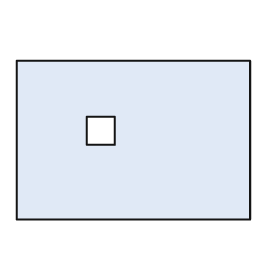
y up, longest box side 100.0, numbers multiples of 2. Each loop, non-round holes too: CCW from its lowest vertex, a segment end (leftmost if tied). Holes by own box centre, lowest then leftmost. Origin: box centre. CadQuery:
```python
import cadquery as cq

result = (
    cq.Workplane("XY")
    .moveTo(-50.0, -34.0)
    .lineTo(50.0, -34.0)
    .lineTo(50.0, 34.0)
    .lineTo(-50.0, 34.0)
    .close()
    .moveTo(-20.0, -2.0)
    .lineTo(-8.0, -2.0)
    .lineTo(-8.0, 10.0)
    .lineTo(-20.0, 10.0)
    .close()
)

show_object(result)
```